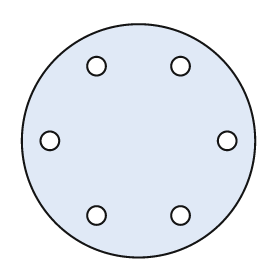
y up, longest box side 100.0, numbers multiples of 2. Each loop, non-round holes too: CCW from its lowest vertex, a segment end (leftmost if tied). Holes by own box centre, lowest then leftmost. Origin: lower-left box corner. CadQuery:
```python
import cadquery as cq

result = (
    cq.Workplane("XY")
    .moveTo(50.0, 50.0)
    .circle(50.0)
    .moveTo(32.0, 18.0)
    .circle(4.0)
    .moveTo(68.0, 18.0)
    .circle(4.0)
    .moveTo(12.0, 50.0)
    .circle(4.0)
    .moveTo(88.0, 50.0)
    .circle(4.0)
    .moveTo(32.0, 82.0)
    .circle(4.0)
    .moveTo(68.0, 82.0)
    .circle(4.0)
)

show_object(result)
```